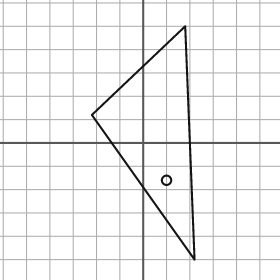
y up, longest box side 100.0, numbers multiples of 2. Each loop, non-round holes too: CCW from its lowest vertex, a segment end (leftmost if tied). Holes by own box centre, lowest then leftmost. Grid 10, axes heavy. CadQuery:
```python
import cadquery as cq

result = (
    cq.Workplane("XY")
    .moveTo(22.0, -50.0)
    .lineTo(18.0, 50.0)
    .lineTo(-22.0, 12.0)
    .close()
    .moveTo(10.0, -16.0)
    .circle(2.0)
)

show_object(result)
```